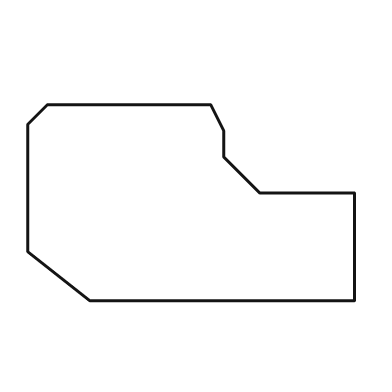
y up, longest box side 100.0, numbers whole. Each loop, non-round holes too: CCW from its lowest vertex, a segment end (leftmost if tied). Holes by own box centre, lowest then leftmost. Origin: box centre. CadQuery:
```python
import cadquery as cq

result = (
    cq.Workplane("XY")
    .moveTo(-31.0, -30.0)
    .lineTo(50.0, -30.0)
    .lineTo(50.0, 3.0)
    .lineTo(21.0, 3.0)
    .lineTo(10.0, 14.0)
    .lineTo(10.0, 22.0)
    .lineTo(6.0, 30.0)
    .lineTo(-44.0, 30.0)
    .lineTo(-50.0, 24.0)
    .lineTo(-50.0, -15.0)
    .close()
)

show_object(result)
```